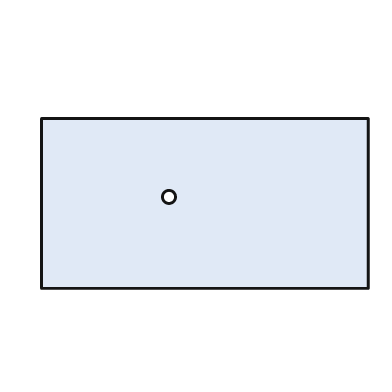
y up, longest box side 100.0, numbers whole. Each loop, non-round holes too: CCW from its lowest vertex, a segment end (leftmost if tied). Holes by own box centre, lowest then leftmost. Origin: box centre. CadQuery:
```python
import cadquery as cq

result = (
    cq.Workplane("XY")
    .moveTo(-50.0, -26.0)
    .lineTo(50.0, -26.0)
    .lineTo(50.0, 26.0)
    .lineTo(-50.0, 26.0)
    .close()
    .moveTo(-11.0, 2.0)
    .circle(2.0)
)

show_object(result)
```